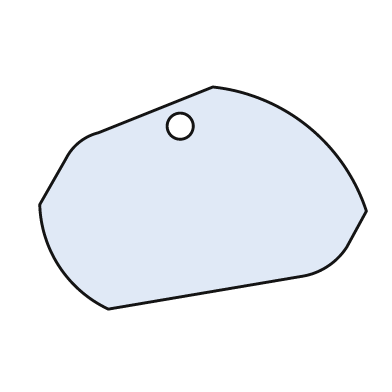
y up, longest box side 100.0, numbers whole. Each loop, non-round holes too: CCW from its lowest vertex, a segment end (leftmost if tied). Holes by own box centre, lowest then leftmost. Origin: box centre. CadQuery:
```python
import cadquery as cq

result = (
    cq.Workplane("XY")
    .moveTo(-29.0, -34.0)
    .lineTo(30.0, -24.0)
    .threePointArc((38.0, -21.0), (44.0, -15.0))
    .lineTo(50.0, -4.0)
    .threePointArc((32.0, 22.0), (3.0, 34.0))
    .lineTo(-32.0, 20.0)
    .threePointArc((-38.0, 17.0), (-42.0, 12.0))
    .lineTo(-50.0, -2.0)
    .threePointArc((-44.0, -21.0), (-29.0, -34.0))
    .close()
    .moveTo(-7.0, 22.0)
    .circle(4.0)
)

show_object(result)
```